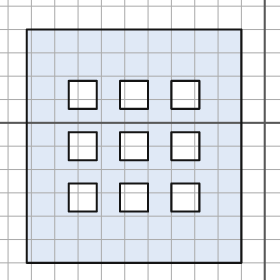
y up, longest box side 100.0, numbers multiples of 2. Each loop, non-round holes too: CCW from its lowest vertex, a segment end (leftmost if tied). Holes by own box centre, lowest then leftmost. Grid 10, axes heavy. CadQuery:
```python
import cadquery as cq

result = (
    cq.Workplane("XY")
    .moveTo(-102.0, -60.0)
    .lineTo(-10.0, -60.0)
    .lineTo(-10.0, 40.0)
    .lineTo(-102.0, 40.0)
    .close()
    .moveTo(-84.0, -38.0)
    .lineTo(-72.0, -38.0)
    .lineTo(-72.0, -26.0)
    .lineTo(-84.0, -26.0)
    .close()
    .moveTo(-62.0, -38.0)
    .lineTo(-50.0, -38.0)
    .lineTo(-50.0, -26.0)
    .lineTo(-62.0, -26.0)
    .close()
    .moveTo(-40.0, -38.0)
    .lineTo(-28.0, -38.0)
    .lineTo(-28.0, -26.0)
    .lineTo(-40.0, -26.0)
    .close()
    .moveTo(-84.0, -16.0)
    .lineTo(-72.0, -16.0)
    .lineTo(-72.0, -4.0)
    .lineTo(-84.0, -4.0)
    .close()
    .moveTo(-62.0, -16.0)
    .lineTo(-50.0, -16.0)
    .lineTo(-50.0, -4.0)
    .lineTo(-62.0, -4.0)
    .close()
    .moveTo(-40.0, -16.0)
    .lineTo(-28.0, -16.0)
    .lineTo(-28.0, -4.0)
    .lineTo(-40.0, -4.0)
    .close()
    .moveTo(-84.0, 6.0)
    .lineTo(-72.0, 6.0)
    .lineTo(-72.0, 18.0)
    .lineTo(-84.0, 18.0)
    .close()
    .moveTo(-62.0, 6.0)
    .lineTo(-50.0, 6.0)
    .lineTo(-50.0, 18.0)
    .lineTo(-62.0, 18.0)
    .close()
    .moveTo(-40.0, 6.0)
    .lineTo(-28.0, 6.0)
    .lineTo(-28.0, 18.0)
    .lineTo(-40.0, 18.0)
    .close()
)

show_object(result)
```